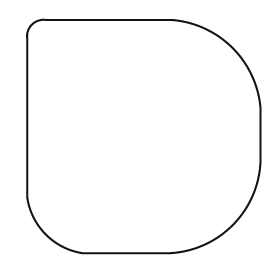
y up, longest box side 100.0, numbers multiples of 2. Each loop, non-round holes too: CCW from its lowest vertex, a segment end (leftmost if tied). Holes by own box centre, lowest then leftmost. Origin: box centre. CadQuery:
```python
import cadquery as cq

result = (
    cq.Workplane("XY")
    .moveTo(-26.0, -50.0)
    .lineTo(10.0, -50.0)
    .threePointArc((38.0, -38.0), (50.0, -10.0))
    .lineTo(50.0, 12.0)
    .threePointArc((38.0, 38.0), (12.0, 50.0))
    .lineTo(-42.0, 50.0)
    .threePointArc((-48.0, 48.0), (-50.0, 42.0))
    .lineTo(-50.0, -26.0)
    .threePointArc((-42.0, -42.0), (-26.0, -50.0))
    .close()
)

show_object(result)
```